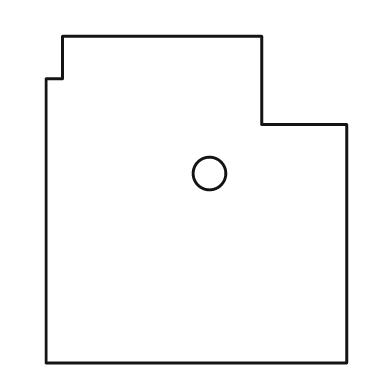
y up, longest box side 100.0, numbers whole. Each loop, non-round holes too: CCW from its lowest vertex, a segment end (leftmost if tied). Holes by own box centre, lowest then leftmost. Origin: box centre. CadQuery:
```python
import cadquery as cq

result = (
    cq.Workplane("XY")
    .moveTo(-46.0, -50.0)
    .lineTo(46.0, -50.0)
    .lineTo(46.0, 23.0)
    .lineTo(20.0, 23.0)
    .lineTo(20.0, 50.0)
    .lineTo(-41.0, 50.0)
    .lineTo(-41.0, 37.0)
    .lineTo(-46.0, 37.0)
    .close()
    .moveTo(4.0, 8.0)
    .circle(5.0)
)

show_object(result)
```